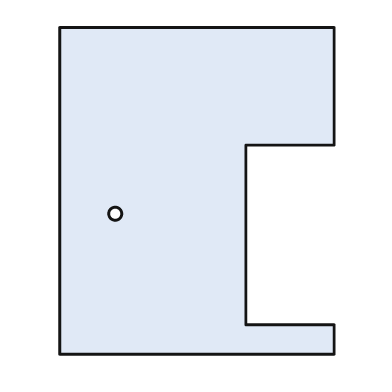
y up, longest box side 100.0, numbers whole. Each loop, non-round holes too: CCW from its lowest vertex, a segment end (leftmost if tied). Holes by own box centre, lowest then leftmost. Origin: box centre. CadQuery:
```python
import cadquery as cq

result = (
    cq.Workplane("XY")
    .moveTo(-42.0, -50.0)
    .lineTo(42.0, -50.0)
    .lineTo(42.0, -41.0)
    .lineTo(15.0, -41.0)
    .lineTo(15.0, 14.0)
    .lineTo(42.0, 14.0)
    .lineTo(42.0, 50.0)
    .lineTo(-42.0, 50.0)
    .close()
    .moveTo(-25.0, -7.0)
    .circle(2.0)
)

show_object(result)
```